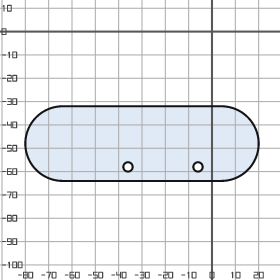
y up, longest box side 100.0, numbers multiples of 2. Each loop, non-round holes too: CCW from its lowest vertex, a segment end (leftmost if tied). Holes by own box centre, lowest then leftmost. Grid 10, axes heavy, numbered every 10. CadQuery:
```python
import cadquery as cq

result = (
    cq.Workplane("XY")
    .moveTo(-64.0, -64.0)
    .lineTo(4.0, -64.0)
    .threePointArc((20.0, -48.0), (4.0, -32.0))
    .lineTo(-64.0, -32.0)
    .threePointArc((-80.0, -48.0), (-64.0, -64.0))
    .close()
    .moveTo(-36.0, -58.0)
    .circle(2.0)
    .moveTo(-6.0, -58.0)
    .circle(2.0)
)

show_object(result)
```